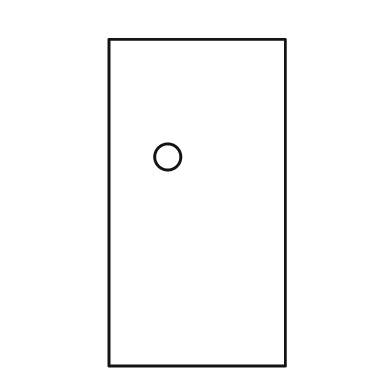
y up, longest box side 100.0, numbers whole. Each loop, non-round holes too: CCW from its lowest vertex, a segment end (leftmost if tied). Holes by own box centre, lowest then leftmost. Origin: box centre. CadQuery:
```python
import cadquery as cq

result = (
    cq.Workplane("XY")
    .moveTo(-27.0, -50.0)
    .lineTo(27.0, -50.0)
    .lineTo(27.0, 50.0)
    .lineTo(-27.0, 50.0)
    .close()
    .moveTo(-9.0, 14.0)
    .circle(4.0)
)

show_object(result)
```